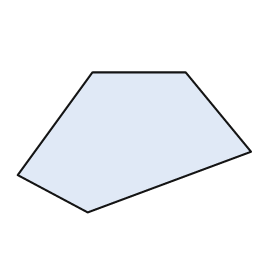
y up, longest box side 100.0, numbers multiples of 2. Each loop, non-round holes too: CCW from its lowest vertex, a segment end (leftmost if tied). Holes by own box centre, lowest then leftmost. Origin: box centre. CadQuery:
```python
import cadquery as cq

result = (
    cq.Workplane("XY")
    .moveTo(-20.0, -30.0)
    .lineTo(50.0, -4.0)
    .lineTo(22.0, 30.0)
    .lineTo(-18.0, 30.0)
    .lineTo(-50.0, -14.0)
    .close()
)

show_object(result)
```